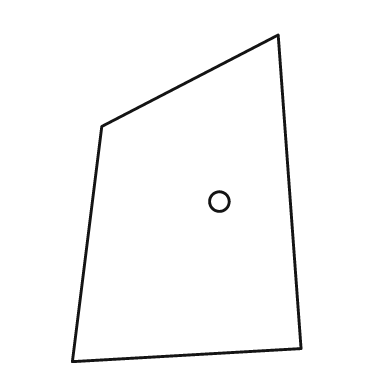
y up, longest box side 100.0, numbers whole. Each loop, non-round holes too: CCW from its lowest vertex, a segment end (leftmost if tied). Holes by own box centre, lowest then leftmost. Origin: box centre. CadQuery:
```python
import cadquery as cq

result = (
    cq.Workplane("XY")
    .moveTo(-35.0, -50.0)
    .lineTo(35.0, -46.0)
    .lineTo(28.0, 50.0)
    .lineTo(-26.0, 22.0)
    .close()
    .moveTo(10.0, -1.0)
    .circle(3.0)
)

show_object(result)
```